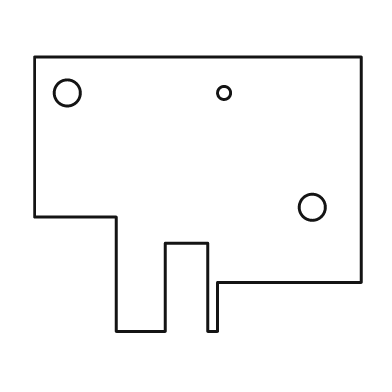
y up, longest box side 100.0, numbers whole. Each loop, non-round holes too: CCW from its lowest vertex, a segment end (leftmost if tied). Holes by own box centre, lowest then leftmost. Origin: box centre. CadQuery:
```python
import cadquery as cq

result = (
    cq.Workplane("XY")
    .moveTo(-25.0, -42.0)
    .lineTo(-10.0, -42.0)
    .lineTo(-10.0, -15.0)
    .lineTo(3.0, -15.0)
    .lineTo(3.0, -42.0)
    .lineTo(6.0, -42.0)
    .lineTo(6.0, -27.0)
    .lineTo(50.0, -27.0)
    .lineTo(50.0, 42.0)
    .lineTo(-50.0, 42.0)
    .lineTo(-50.0, -7.0)
    .lineTo(-25.0, -7.0)
    .close()
    .moveTo(35.0, -4.0)
    .circle(4.0)
    .moveTo(-40.0, 31.0)
    .circle(4.0)
    .moveTo(8.0, 31.0)
    .circle(2.0)
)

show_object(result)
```